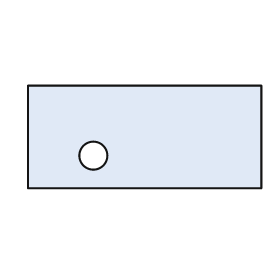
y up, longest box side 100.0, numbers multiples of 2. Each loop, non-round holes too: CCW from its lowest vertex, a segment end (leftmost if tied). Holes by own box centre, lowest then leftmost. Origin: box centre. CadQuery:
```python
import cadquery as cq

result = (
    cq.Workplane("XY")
    .moveTo(-50.0, -22.0)
    .lineTo(50.0, -22.0)
    .lineTo(50.0, 22.0)
    .lineTo(-50.0, 22.0)
    .close()
    .moveTo(-22.0, -8.0)
    .circle(6.0)
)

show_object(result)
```